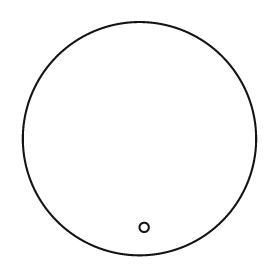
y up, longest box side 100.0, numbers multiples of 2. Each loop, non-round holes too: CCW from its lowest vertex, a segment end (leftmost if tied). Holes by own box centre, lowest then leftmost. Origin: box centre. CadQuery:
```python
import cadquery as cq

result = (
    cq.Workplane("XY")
    .moveTo(0.0, 0.0)
    .circle(50.0)
    .moveTo(2.0, -38.0)
    .circle(2.0)
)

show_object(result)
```